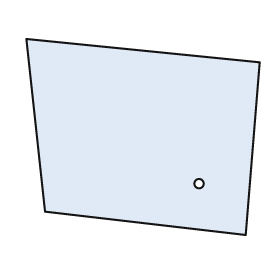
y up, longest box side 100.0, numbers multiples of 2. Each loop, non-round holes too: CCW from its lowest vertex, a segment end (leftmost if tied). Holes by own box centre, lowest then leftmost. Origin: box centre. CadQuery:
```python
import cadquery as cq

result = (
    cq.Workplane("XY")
    .moveTo(44.0, -42.0)
    .lineTo(50.0, 32.0)
    .lineTo(-50.0, 42.0)
    .lineTo(-42.0, -32.0)
    .close()
    .moveTo(24.0, -20.0)
    .circle(2.0)
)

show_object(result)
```